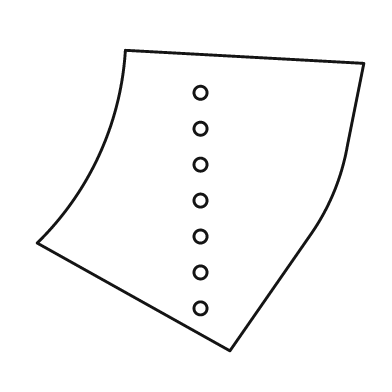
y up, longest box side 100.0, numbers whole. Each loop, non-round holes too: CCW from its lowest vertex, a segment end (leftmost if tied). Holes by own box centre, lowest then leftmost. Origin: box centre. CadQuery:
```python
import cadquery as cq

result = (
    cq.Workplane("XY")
    .moveTo(9.0, -46.0)
    .lineTo(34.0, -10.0)
    .threePointArc((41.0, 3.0), (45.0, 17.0))
    .lineTo(50.0, 42.0)
    .lineTo(-23.0, 46.0)
    .threePointArc((-31.0, 14.0), (-50.0, -13.0))
    .close()
    .moveTo(0.0, -33.0)
    .circle(2.0)
    .moveTo(0.0, -22.0)
    .circle(2.0)
    .moveTo(0.0, -11.0)
    .circle(2.0)
    .moveTo(0.0, 0.0)
    .circle(2.0)
    .moveTo(0.0, 11.0)
    .circle(2.0)
    .moveTo(0.0, 22.0)
    .circle(2.0)
    .moveTo(0.0, 33.0)
    .circle(2.0)
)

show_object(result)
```